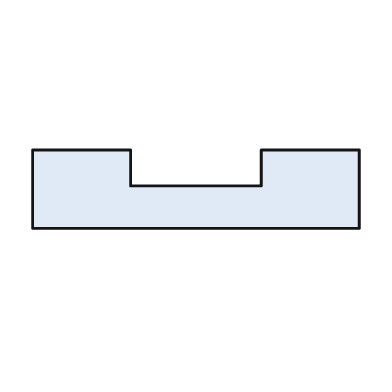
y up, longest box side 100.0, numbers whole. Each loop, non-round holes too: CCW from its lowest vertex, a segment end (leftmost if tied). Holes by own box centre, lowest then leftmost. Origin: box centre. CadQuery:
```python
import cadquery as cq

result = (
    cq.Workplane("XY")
    .moveTo(-50.0, -12.0)
    .lineTo(50.0, -12.0)
    .lineTo(50.0, 12.0)
    .lineTo(20.0, 12.0)
    .lineTo(20.0, 1.0)
    .lineTo(-20.0, 1.0)
    .lineTo(-20.0, 12.0)
    .lineTo(-50.0, 12.0)
    .close()
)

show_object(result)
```